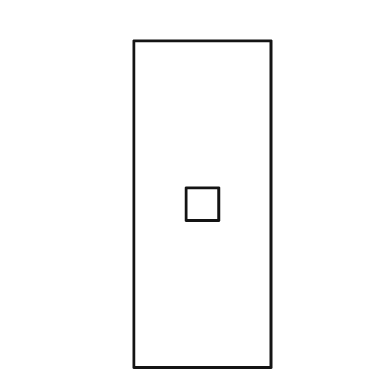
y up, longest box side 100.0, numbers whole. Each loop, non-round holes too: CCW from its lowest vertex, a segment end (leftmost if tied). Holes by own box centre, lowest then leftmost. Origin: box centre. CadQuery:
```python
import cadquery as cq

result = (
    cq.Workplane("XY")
    .moveTo(-21.0, -50.0)
    .lineTo(21.0, -50.0)
    .lineTo(21.0, 50.0)
    .lineTo(-21.0, 50.0)
    .close()
    .moveTo(-5.0, -5.0)
    .lineTo(5.0, -5.0)
    .lineTo(5.0, 5.0)
    .lineTo(-5.0, 5.0)
    .close()
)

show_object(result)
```